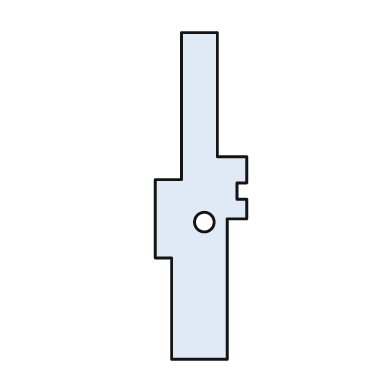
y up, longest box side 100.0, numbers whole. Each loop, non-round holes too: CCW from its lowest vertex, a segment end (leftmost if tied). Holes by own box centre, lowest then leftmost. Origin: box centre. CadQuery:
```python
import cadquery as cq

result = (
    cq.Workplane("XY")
    .moveTo(-9.0, -50.0)
    .lineTo(8.0, -50.0)
    .lineTo(8.0, -7.0)
    .lineTo(14.0, -7.0)
    .lineTo(14.0, -1.0)
    .lineTo(11.0, -1.0)
    .lineTo(11.0, 4.0)
    .lineTo(14.0, 4.0)
    .lineTo(14.0, 12.0)
    .lineTo(5.0, 12.0)
    .lineTo(5.0, 50.0)
    .lineTo(-6.0, 50.0)
    .lineTo(-6.0, 5.0)
    .lineTo(-14.0, 5.0)
    .lineTo(-14.0, -19.0)
    .lineTo(-9.0, -19.0)
    .close()
    .moveTo(1.0, -8.0)
    .circle(3.0)
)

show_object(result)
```